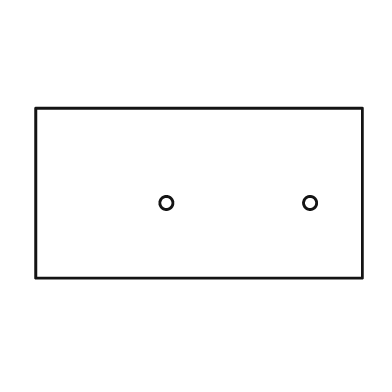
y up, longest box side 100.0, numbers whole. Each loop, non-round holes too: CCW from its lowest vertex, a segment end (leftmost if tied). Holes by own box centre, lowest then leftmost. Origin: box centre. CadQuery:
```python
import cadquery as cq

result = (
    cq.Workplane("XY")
    .moveTo(-50.0, -26.0)
    .lineTo(50.0, -26.0)
    .lineTo(50.0, 26.0)
    .lineTo(-50.0, 26.0)
    .close()
    .moveTo(-10.0, -3.0)
    .circle(2.0)
    .moveTo(34.0, -3.0)
    .circle(2.0)
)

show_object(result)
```